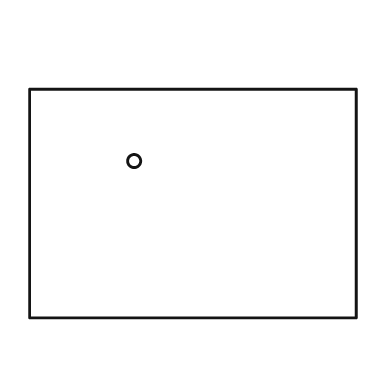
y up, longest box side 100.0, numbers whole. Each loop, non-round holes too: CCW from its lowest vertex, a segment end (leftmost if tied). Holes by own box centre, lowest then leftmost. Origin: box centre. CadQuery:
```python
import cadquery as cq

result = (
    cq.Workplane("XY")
    .moveTo(-50.0, -35.0)
    .lineTo(50.0, -35.0)
    .lineTo(50.0, 35.0)
    .lineTo(-50.0, 35.0)
    .close()
    .moveTo(-18.0, 13.0)
    .circle(2.0)
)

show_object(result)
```